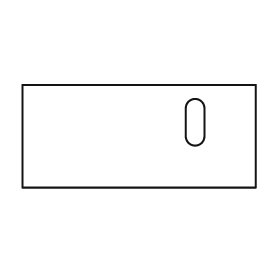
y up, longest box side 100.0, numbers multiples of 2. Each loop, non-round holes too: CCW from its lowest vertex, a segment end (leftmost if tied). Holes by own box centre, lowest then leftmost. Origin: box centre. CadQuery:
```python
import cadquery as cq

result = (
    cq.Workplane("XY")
    .moveTo(-50.0, -22.0)
    .lineTo(50.0, -22.0)
    .lineTo(50.0, 22.0)
    .lineTo(-50.0, 22.0)
    .close()
    .moveTo(20.0, 0.0)
    .threePointArc((24.0, -4.0), (28.0, 0.0))
    .lineTo(28.0, 12.0)
    .threePointArc((24.0, 16.0), (20.0, 12.0))
    .close()
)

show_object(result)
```